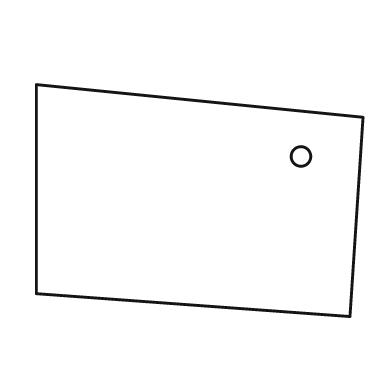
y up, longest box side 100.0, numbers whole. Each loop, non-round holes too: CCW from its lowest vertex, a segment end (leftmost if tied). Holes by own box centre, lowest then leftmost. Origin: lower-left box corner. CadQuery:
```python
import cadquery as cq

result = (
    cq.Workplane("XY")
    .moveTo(96.0, 0.0)
    .lineTo(100.0, 61.0)
    .lineTo(0.0, 71.0)
    .lineTo(0.0, 7.0)
    .close()
    .moveTo(81.0, 49.0)
    .circle(3.0)
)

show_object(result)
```